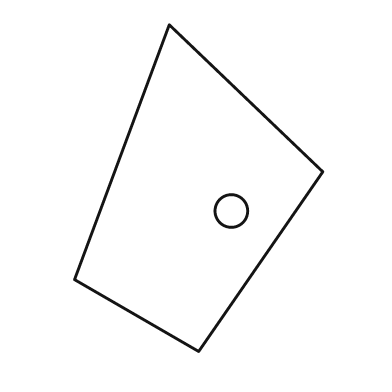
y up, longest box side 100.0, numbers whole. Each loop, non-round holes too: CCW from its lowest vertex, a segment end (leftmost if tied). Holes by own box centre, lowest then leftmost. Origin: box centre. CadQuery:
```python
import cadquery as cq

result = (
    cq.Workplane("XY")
    .moveTo(0.0, -50.0)
    .lineTo(38.0, 5.0)
    .lineTo(-9.0, 50.0)
    .lineTo(-38.0, -28.0)
    .close()
    .moveTo(10.0, -7.0)
    .circle(5.0)
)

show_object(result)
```